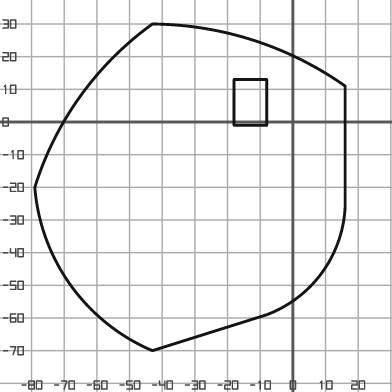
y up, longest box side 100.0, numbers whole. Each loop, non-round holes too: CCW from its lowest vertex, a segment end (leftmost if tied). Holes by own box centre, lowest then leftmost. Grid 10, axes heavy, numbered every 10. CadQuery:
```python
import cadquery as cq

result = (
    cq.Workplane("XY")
    .moveTo(-43.0, -70.0)
    .lineTo(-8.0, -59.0)
    .threePointArc((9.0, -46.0), (16.0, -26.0))
    .lineTo(16.0, 11.0)
    .threePointArc((-12.0, 25.0), (-43.0, 30.0))
    .threePointArc((-65.0, 8.0), (-79.0, -20.0))
    .threePointArc((-68.0, -50.0), (-43.0, -70.0))
    .close()
    .moveTo(-18.0, -1.0)
    .lineTo(-8.0, -1.0)
    .lineTo(-8.0, 13.0)
    .lineTo(-18.0, 13.0)
    .close()
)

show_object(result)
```